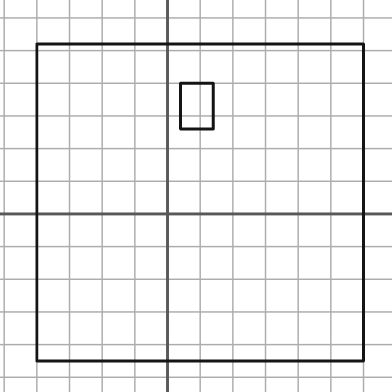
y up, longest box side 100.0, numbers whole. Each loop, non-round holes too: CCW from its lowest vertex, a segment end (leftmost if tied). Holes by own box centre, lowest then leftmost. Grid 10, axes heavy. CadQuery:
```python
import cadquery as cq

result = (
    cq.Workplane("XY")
    .moveTo(-40.0, -45.0)
    .lineTo(60.0, -45.0)
    .lineTo(60.0, 52.0)
    .lineTo(-40.0, 52.0)
    .close()
    .moveTo(4.0, 26.0)
    .lineTo(14.0, 26.0)
    .lineTo(14.0, 40.0)
    .lineTo(4.0, 40.0)
    .close()
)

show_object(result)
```